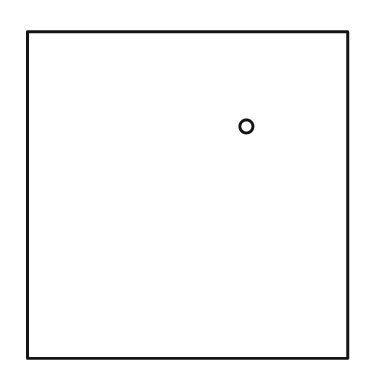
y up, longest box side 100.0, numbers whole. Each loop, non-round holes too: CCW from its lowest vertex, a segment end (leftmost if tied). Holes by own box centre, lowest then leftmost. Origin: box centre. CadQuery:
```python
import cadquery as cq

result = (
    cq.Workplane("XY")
    .moveTo(-49.0, -50.0)
    .lineTo(49.0, -50.0)
    .lineTo(49.0, 50.0)
    .lineTo(-49.0, 50.0)
    .close()
    .moveTo(18.0, 21.0)
    .circle(2.0)
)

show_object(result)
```